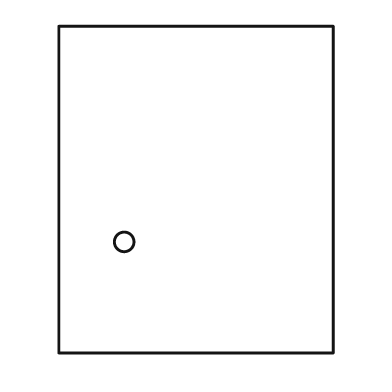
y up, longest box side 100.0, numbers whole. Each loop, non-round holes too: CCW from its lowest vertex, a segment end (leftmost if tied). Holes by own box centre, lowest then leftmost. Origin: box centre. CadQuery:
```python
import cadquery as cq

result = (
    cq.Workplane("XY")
    .moveTo(-42.0, -50.0)
    .lineTo(42.0, -50.0)
    .lineTo(42.0, 50.0)
    .lineTo(-42.0, 50.0)
    .close()
    .moveTo(-22.0, -16.0)
    .circle(3.0)
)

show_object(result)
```